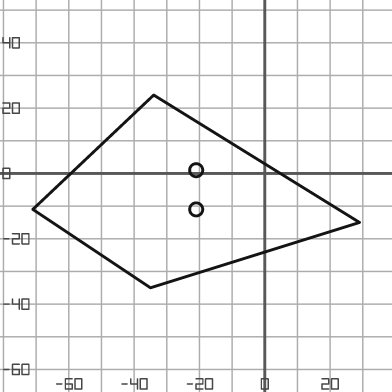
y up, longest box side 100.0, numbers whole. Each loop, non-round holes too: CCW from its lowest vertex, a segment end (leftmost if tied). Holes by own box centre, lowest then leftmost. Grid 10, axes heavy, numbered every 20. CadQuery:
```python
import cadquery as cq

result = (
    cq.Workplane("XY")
    .moveTo(-35.0, -35.0)
    .lineTo(29.0, -15.0)
    .lineTo(-34.0, 24.0)
    .lineTo(-71.0, -11.0)
    .close()
    .moveTo(-21.0, -11.0)
    .circle(2.0)
    .moveTo(-21.0, 1.0)
    .circle(2.0)
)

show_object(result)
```